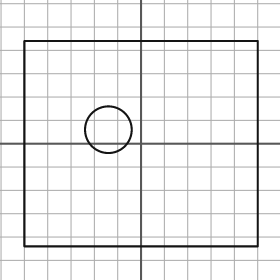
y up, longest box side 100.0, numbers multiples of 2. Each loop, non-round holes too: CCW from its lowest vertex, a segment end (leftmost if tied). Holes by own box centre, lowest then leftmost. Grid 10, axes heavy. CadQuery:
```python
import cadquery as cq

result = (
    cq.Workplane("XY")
    .moveTo(-50.0, -44.0)
    .lineTo(50.0, -44.0)
    .lineTo(50.0, 44.0)
    .lineTo(-50.0, 44.0)
    .close()
    .moveTo(-14.0, 6.0)
    .circle(10.0)
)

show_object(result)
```